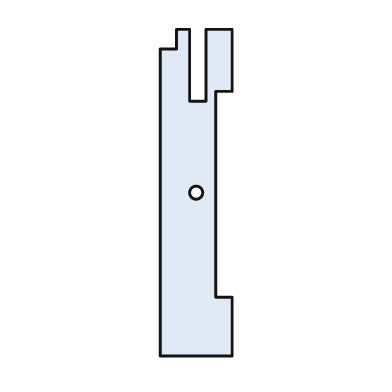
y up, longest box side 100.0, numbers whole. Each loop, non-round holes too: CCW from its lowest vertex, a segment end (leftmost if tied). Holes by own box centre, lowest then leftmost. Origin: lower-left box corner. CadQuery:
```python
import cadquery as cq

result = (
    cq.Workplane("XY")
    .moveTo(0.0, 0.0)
    .lineTo(22.0, 0.0)
    .lineTo(22.0, 18.0)
    .lineTo(17.0, 18.0)
    .lineTo(17.0, 81.0)
    .lineTo(22.0, 81.0)
    .lineTo(22.0, 100.0)
    .lineTo(14.0, 100.0)
    .lineTo(14.0, 78.0)
    .lineTo(9.0, 78.0)
    .lineTo(9.0, 100.0)
    .lineTo(5.0, 100.0)
    .lineTo(5.0, 94.0)
    .lineTo(0.0, 94.0)
    .close()
    .moveTo(11.0, 50.0)
    .circle(2.0)
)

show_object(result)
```